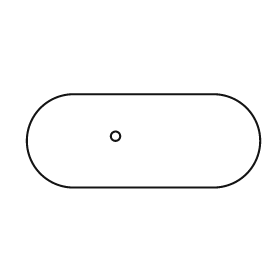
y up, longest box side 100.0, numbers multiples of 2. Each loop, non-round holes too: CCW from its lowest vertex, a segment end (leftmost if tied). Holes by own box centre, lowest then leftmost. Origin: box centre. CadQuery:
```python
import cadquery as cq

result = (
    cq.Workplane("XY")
    .moveTo(-30.0, -20.0)
    .lineTo(30.0, -20.0)
    .threePointArc((50.0, 0.0), (30.0, 20.0))
    .lineTo(-30.0, 20.0)
    .threePointArc((-50.0, 0.0), (-30.0, -20.0))
    .close()
    .moveTo(-12.0, 2.0)
    .circle(2.0)
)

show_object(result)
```